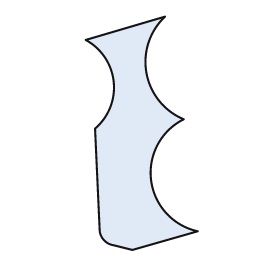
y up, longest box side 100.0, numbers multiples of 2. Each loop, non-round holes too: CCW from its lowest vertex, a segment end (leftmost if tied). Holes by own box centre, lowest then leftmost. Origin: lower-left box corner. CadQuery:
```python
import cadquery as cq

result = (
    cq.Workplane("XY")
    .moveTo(20.0, 0.0)
    .lineTo(48.0, 8.0)
    .threePointArc((28.0, 30.0), (42.0, 56.0))
    .threePointArc((26.0, 76.0), (34.0, 100.0))
    .lineTo(0.0, 90.0)
    .threePointArc((12.0, 72.0), (4.0, 52.0))
    .lineTo(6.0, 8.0)
    .threePointArc((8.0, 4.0), (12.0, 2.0))
    .close()
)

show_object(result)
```